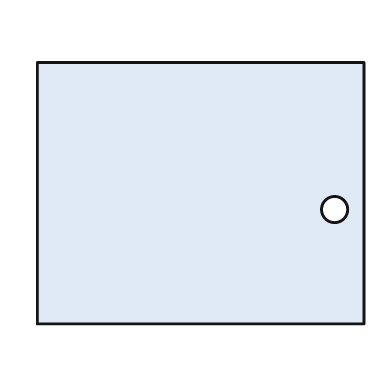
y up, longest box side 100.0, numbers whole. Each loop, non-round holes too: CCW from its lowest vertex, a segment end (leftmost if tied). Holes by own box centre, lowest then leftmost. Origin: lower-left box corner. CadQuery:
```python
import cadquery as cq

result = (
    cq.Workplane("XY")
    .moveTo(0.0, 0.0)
    .lineTo(100.0, 0.0)
    .lineTo(100.0, 80.0)
    .lineTo(0.0, 80.0)
    .close()
    .moveTo(91.0, 35.0)
    .circle(4.0)
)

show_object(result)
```